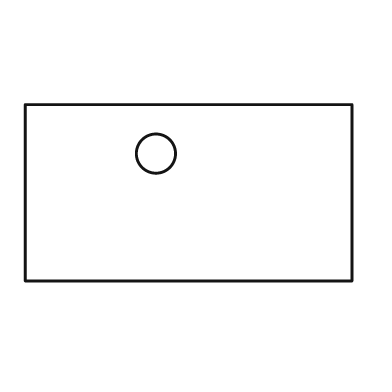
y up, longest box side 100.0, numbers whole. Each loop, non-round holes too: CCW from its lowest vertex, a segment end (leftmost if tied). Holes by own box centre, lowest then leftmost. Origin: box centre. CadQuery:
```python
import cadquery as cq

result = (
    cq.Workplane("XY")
    .moveTo(-50.0, -27.0)
    .lineTo(50.0, -27.0)
    .lineTo(50.0, 27.0)
    .lineTo(-50.0, 27.0)
    .close()
    .moveTo(-10.0, 12.0)
    .circle(6.0)
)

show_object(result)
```